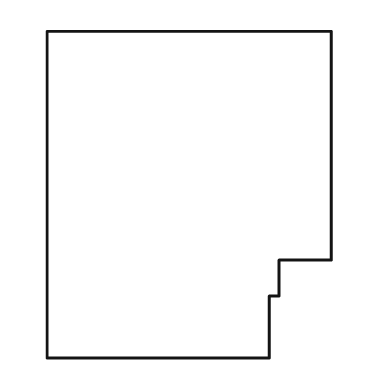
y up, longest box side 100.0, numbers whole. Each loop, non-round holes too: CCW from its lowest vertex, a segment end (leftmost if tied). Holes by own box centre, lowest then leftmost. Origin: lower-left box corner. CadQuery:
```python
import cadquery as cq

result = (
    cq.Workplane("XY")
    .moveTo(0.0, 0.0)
    .lineTo(68.0, 0.0)
    .lineTo(68.0, 19.0)
    .lineTo(71.0, 19.0)
    .lineTo(71.0, 30.0)
    .lineTo(87.0, 30.0)
    .lineTo(87.0, 100.0)
    .lineTo(0.0, 100.0)
    .close()
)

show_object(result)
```